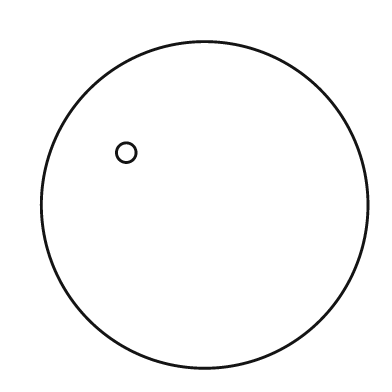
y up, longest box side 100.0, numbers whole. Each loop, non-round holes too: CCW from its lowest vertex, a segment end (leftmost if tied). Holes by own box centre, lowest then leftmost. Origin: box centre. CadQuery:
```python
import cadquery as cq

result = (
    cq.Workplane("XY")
    .moveTo(0.0, 0.0)
    .circle(50.0)
    .moveTo(-24.0, 16.0)
    .circle(3.0)
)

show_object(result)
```